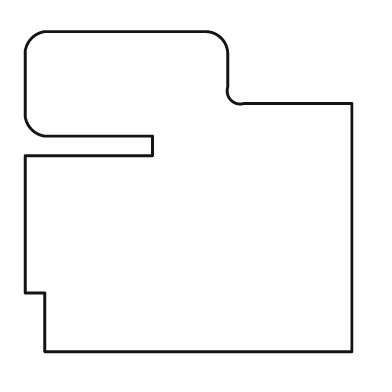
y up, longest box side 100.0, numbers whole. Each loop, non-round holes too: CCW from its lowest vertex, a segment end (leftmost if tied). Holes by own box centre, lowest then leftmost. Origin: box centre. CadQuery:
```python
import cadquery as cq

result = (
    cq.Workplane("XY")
    .moveTo(-44.0, -49.0)
    .lineTo(50.0, -49.0)
    .lineTo(50.0, 27.0)
    .lineTo(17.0, 27.0)
    .threePointArc((13.0, 28.0), (12.0, 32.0))
    .lineTo(12.0, 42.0)
    .threePointArc((10.0, 47.0), (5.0, 49.0))
    .lineTo(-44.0, 49.0)
    .threePointArc((-48.0, 47.0), (-50.0, 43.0))
    .lineTo(-50.0, 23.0)
    .threePointArc((-48.0, 19.0), (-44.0, 17.0))
    .lineTo(-11.0, 17.0)
    .lineTo(-11.0, 11.0)
    .lineTo(-50.0, 11.0)
    .lineTo(-50.0, -31.0)
    .lineTo(-44.0, -31.0)
    .close()
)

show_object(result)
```